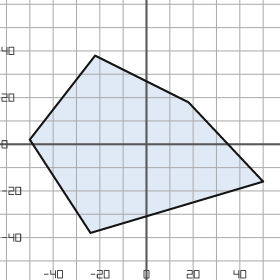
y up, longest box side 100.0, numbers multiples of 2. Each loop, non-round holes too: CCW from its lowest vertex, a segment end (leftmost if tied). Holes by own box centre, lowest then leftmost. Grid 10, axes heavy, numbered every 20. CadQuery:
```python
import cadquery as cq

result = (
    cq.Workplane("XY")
    .moveTo(-24.0, -38.0)
    .lineTo(50.0, -16.0)
    .lineTo(18.0, 18.0)
    .lineTo(-22.0, 38.0)
    .lineTo(-50.0, 2.0)
    .close()
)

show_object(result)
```